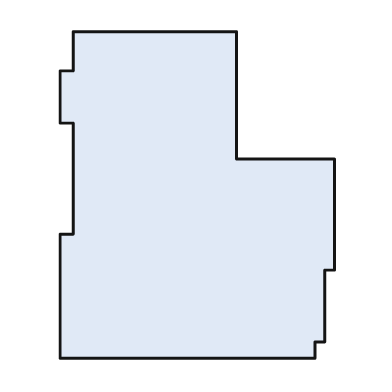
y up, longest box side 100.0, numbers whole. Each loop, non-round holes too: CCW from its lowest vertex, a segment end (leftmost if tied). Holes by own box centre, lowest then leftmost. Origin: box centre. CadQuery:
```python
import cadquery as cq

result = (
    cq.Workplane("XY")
    .moveTo(-42.0, -50.0)
    .lineTo(36.0, -50.0)
    .lineTo(36.0, -45.0)
    .lineTo(39.0, -45.0)
    .lineTo(39.0, -23.0)
    .lineTo(42.0, -23.0)
    .lineTo(42.0, 11.0)
    .lineTo(12.0, 11.0)
    .lineTo(12.0, 50.0)
    .lineTo(-38.0, 50.0)
    .lineTo(-38.0, 38.0)
    .lineTo(-42.0, 38.0)
    .lineTo(-42.0, 22.0)
    .lineTo(-38.0, 22.0)
    .lineTo(-38.0, -12.0)
    .lineTo(-42.0, -12.0)
    .close()
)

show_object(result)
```